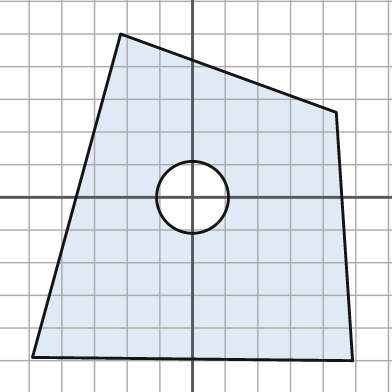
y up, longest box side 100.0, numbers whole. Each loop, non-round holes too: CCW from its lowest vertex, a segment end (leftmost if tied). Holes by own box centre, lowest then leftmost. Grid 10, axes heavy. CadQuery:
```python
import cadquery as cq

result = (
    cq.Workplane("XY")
    .moveTo(49.0, -50.0)
    .lineTo(44.0, 26.0)
    .lineTo(-22.0, 50.0)
    .lineTo(-49.0, -49.0)
    .close()
    .moveTo(0.0, 0.0)
    .circle(11.0)
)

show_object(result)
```